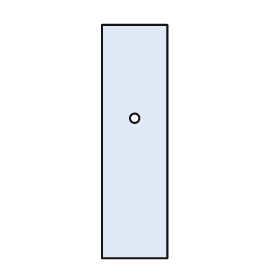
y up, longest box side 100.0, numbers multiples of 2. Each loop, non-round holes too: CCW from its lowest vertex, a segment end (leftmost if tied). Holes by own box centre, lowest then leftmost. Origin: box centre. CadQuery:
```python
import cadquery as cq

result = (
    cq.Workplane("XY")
    .moveTo(-14.0, -50.0)
    .lineTo(14.0, -50.0)
    .lineTo(14.0, 50.0)
    .lineTo(-14.0, 50.0)
    .close()
    .moveTo(0.0, 10.0)
    .circle(2.0)
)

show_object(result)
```